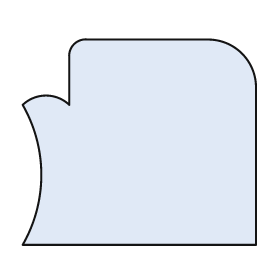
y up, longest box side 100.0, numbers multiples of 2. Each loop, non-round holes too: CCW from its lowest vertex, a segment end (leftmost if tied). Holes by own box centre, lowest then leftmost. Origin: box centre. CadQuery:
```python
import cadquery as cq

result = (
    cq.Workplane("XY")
    .moveTo(-50.0, -44.0)
    .lineTo(50.0, -44.0)
    .lineTo(50.0, 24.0)
    .threePointArc((44.0, 38.0), (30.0, 44.0))
    .lineTo(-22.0, 44.0)
    .threePointArc((-28.0, 42.0), (-30.0, 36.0))
    .lineTo(-30.0, 16.0)
    .threePointArc((-40.0, 20.0), (-50.0, 16.0))
    .threePointArc((-42.0, -14.0), (-50.0, -44.0))
    .close()
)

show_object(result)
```